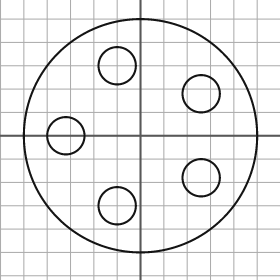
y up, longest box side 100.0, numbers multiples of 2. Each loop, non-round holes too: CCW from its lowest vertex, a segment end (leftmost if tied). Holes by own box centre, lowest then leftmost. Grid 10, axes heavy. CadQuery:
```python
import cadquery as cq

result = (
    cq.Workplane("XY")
    .moveTo(0.0, 0.0)
    .circle(50.0)
    .moveTo(-10.0, -30.0)
    .circle(8.0)
    .moveTo(26.0, -18.0)
    .circle(8.0)
    .moveTo(-32.0, 0.0)
    .circle(8.0)
    .moveTo(26.0, 18.0)
    .circle(8.0)
    .moveTo(-10.0, 30.0)
    .circle(8.0)
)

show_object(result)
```